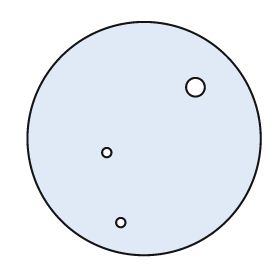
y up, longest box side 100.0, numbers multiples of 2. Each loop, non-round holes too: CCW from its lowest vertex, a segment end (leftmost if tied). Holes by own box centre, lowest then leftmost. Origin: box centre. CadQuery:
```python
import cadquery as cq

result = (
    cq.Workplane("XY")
    .moveTo(0.0, 0.0)
    .circle(50.0)
    .moveTo(-10.0, -36.0)
    .circle(2.0)
    .moveTo(-16.0, -6.0)
    .circle(2.0)
    .moveTo(22.0, 22.0)
    .circle(4.0)
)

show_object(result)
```